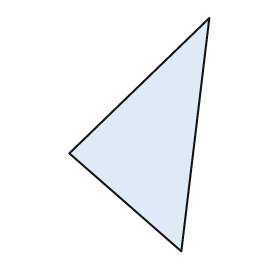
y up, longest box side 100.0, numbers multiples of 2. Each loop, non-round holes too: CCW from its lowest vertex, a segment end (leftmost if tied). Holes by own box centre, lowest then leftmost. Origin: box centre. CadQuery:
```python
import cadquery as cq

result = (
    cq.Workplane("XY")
    .moveTo(18.0, -50.0)
    .lineTo(30.0, 50.0)
    .lineTo(-30.0, -8.0)
    .close()
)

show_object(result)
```